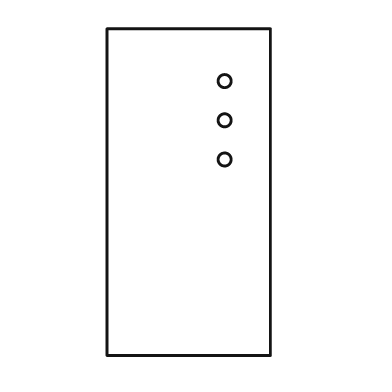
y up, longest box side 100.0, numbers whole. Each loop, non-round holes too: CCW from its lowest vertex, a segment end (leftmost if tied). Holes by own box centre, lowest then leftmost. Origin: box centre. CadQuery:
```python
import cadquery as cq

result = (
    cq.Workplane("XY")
    .moveTo(-25.0, -50.0)
    .lineTo(25.0, -50.0)
    .lineTo(25.0, 50.0)
    .lineTo(-25.0, 50.0)
    .close()
    .moveTo(11.0, 10.0)
    .circle(2.0)
    .moveTo(11.0, 22.0)
    .circle(2.0)
    .moveTo(11.0, 34.0)
    .circle(2.0)
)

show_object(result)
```